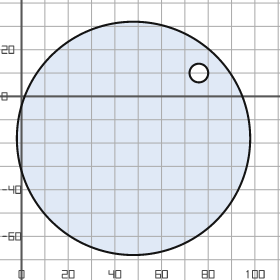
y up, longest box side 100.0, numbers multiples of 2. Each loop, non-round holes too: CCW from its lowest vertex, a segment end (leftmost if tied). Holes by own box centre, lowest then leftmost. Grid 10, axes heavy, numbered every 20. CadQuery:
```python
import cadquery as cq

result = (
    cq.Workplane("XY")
    .moveTo(48.0, -18.0)
    .circle(50.0)
    .moveTo(76.0, 10.0)
    .circle(4.0)
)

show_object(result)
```